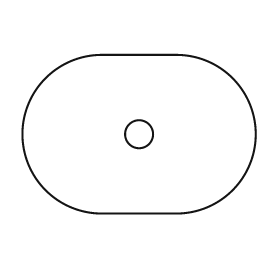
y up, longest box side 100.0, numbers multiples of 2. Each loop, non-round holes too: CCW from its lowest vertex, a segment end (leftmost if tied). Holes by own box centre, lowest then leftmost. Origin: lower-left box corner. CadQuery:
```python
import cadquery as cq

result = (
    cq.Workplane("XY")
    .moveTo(34.0, 0.0)
    .lineTo(66.0, 0.0)
    .threePointArc((100.0, 34.0), (66.0, 68.0))
    .lineTo(34.0, 68.0)
    .threePointArc((0.0, 34.0), (34.0, 0.0))
    .close()
    .moveTo(50.0, 34.0)
    .circle(6.0)
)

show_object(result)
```